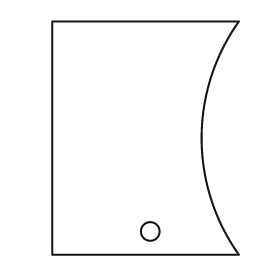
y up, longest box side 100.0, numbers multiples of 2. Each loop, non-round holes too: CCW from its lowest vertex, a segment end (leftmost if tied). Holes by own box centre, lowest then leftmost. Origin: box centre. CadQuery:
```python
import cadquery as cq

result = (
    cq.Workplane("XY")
    .moveTo(-40.0, -50.0)
    .lineTo(40.0, -50.0)
    .threePointArc((24.0, 0.0), (40.0, 50.0))
    .lineTo(-40.0, 50.0)
    .close()
    .moveTo(2.0, -40.0)
    .circle(4.0)
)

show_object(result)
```